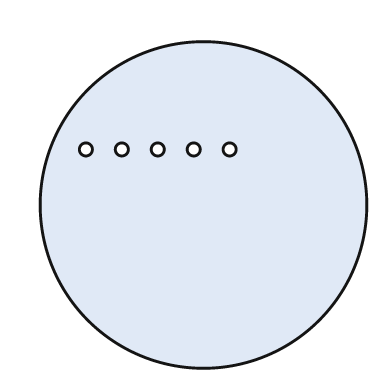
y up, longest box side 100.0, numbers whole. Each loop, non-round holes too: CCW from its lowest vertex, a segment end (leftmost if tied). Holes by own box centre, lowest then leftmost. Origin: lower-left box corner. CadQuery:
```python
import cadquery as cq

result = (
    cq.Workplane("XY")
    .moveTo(50.0, 50.0)
    .circle(50.0)
    .moveTo(14.0, 67.0)
    .circle(2.0)
    .moveTo(25.0, 67.0)
    .circle(2.0)
    .moveTo(36.0, 67.0)
    .circle(2.0)
    .moveTo(47.0, 67.0)
    .circle(2.0)
    .moveTo(58.0, 67.0)
    .circle(2.0)
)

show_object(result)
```